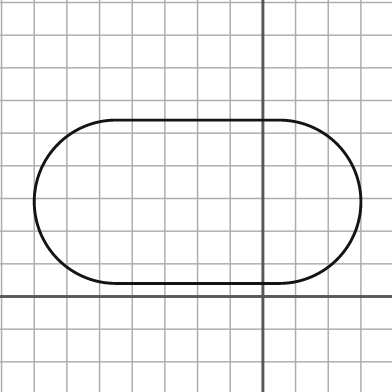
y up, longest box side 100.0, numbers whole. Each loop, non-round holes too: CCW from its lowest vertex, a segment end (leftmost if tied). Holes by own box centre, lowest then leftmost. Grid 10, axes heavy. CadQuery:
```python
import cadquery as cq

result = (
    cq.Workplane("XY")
    .moveTo(-45.0, 4.0)
    .lineTo(5.0, 4.0)
    .threePointArc((30.0, 29.0), (5.0, 54.0))
    .lineTo(-45.0, 54.0)
    .threePointArc((-70.0, 29.0), (-45.0, 4.0))
    .close()
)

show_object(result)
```